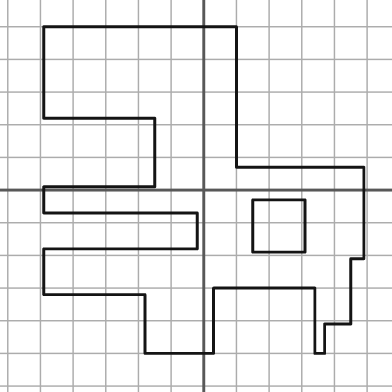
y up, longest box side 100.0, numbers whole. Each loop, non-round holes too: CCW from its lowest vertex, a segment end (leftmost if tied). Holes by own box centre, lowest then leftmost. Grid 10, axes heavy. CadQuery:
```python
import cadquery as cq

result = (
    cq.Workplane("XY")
    .moveTo(-18.0, -50.0)
    .lineTo(3.0, -50.0)
    .lineTo(3.0, -30.0)
    .lineTo(34.0, -30.0)
    .lineTo(34.0, -50.0)
    .lineTo(37.0, -50.0)
    .lineTo(37.0, -41.0)
    .lineTo(45.0, -41.0)
    .lineTo(45.0, -21.0)
    .lineTo(49.0, -21.0)
    .lineTo(49.0, 7.0)
    .lineTo(10.0, 7.0)
    .lineTo(10.0, 50.0)
    .lineTo(-49.0, 50.0)
    .lineTo(-49.0, 22.0)
    .lineTo(-15.0, 22.0)
    .lineTo(-15.0, 1.0)
    .lineTo(-49.0, 1.0)
    .lineTo(-49.0, -7.0)
    .lineTo(-2.0, -7.0)
    .lineTo(-2.0, -18.0)
    .lineTo(-49.0, -18.0)
    .lineTo(-49.0, -32.0)
    .lineTo(-18.0, -32.0)
    .close()
    .moveTo(15.0, -19.0)
    .lineTo(31.0, -19.0)
    .lineTo(31.0, -3.0)
    .lineTo(15.0, -3.0)
    .close()
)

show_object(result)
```